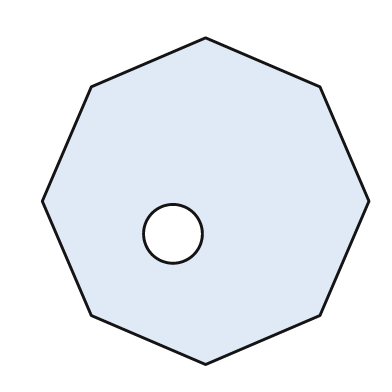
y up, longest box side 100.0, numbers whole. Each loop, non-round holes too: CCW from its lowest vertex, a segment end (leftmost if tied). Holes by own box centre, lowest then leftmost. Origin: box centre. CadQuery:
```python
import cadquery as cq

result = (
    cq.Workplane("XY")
    .moveTo(0.0, -50.0)
    .lineTo(35.0, -35.0)
    .lineTo(50.0, 0.0)
    .lineTo(35.0, 35.0)
    .lineTo(0.0, 50.0)
    .lineTo(-35.0, 35.0)
    .lineTo(-50.0, 0.0)
    .lineTo(-35.0, -35.0)
    .close()
    .moveTo(-10.0, -10.0)
    .circle(9.0)
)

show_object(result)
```